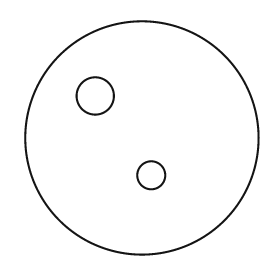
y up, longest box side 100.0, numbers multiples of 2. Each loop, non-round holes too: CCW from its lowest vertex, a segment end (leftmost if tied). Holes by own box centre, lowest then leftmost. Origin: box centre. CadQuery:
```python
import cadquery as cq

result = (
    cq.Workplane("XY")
    .moveTo(0.0, 0.0)
    .circle(50.0)
    .moveTo(4.0, -16.0)
    .circle(6.0)
    .moveTo(-20.0, 18.0)
    .circle(8.0)
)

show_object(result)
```